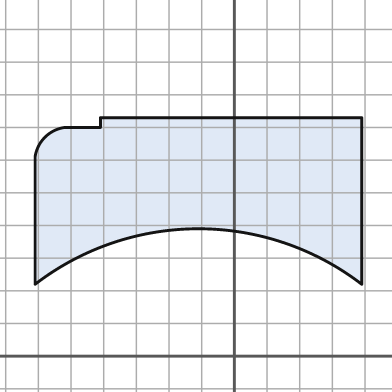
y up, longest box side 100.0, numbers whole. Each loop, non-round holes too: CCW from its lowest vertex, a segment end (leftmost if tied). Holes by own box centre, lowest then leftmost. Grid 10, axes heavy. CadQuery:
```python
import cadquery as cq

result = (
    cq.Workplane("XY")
    .moveTo(-61.0, 22.0)
    .threePointArc((-11.0, 39.0), (39.0, 22.0))
    .lineTo(39.0, 73.0)
    .lineTo(-41.0, 73.0)
    .lineTo(-41.0, 70.0)
    .lineTo(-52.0, 70.0)
    .threePointArc((-58.0, 67.0), (-61.0, 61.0))
    .close()
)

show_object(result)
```